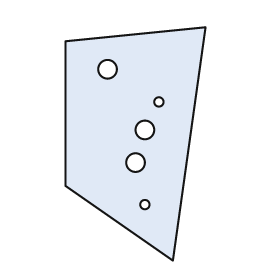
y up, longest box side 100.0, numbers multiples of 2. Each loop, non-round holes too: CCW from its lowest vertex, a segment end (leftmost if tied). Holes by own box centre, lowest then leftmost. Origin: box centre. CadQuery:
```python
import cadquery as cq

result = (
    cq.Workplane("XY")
    .moveTo(16.0, -50.0)
    .lineTo(30.0, 50.0)
    .lineTo(-30.0, 44.0)
    .lineTo(-30.0, -18.0)
    .close()
    .moveTo(4.0, -26.0)
    .circle(2.0)
    .moveTo(0.0, -8.0)
    .circle(4.0)
    .moveTo(4.0, 6.0)
    .circle(4.0)
    .moveTo(10.0, 18.0)
    .circle(2.0)
    .moveTo(-12.0, 32.0)
    .circle(4.0)
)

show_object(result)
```